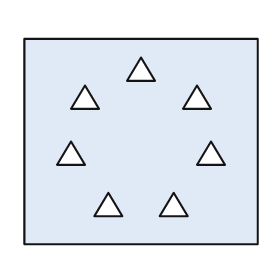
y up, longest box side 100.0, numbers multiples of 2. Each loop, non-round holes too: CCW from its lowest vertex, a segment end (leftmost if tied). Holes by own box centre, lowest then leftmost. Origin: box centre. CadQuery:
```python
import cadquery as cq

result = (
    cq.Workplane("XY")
    .moveTo(-50.0, -44.0)
    .lineTo(50.0, -44.0)
    .lineTo(50.0, 44.0)
    .lineTo(-50.0, 44.0)
    .close()
    .moveTo(-20.0, -32.0)
    .lineTo(-8.0, -32.0)
    .lineTo(-14.0, -22.0)
    .close()
    .moveTo(8.0, -32.0)
    .lineTo(20.0, -32.0)
    .lineTo(14.0, -22.0)
    .close()
    .moveTo(-36.0, -10.0)
    .lineTo(-24.0, -10.0)
    .lineTo(-30.0, 0.0)
    .close()
    .moveTo(24.0, -10.0)
    .lineTo(36.0, -10.0)
    .lineTo(30.0, 0.0)
    .close()
    .moveTo(-30.0, 14.0)
    .lineTo(-18.0, 14.0)
    .lineTo(-24.0, 24.0)
    .close()
    .moveTo(18.0, 14.0)
    .lineTo(30.0, 14.0)
    .lineTo(24.0, 24.0)
    .close()
    .moveTo(-6.0, 26.0)
    .lineTo(6.0, 26.0)
    .lineTo(0.0, 36.0)
    .close()
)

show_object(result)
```